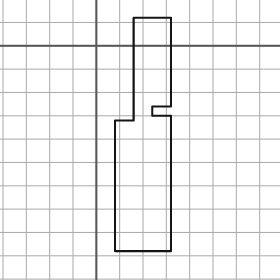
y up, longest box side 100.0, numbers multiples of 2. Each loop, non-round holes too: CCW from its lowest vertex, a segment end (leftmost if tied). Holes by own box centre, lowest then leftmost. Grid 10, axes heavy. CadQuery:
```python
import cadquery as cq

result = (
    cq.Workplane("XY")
    .moveTo(8.0, -88.0)
    .lineTo(32.0, -88.0)
    .lineTo(32.0, -30.0)
    .lineTo(24.0, -30.0)
    .lineTo(24.0, -26.0)
    .lineTo(32.0, -26.0)
    .lineTo(32.0, 12.0)
    .lineTo(16.0, 12.0)
    .lineTo(16.0, -32.0)
    .lineTo(8.0, -32.0)
    .close()
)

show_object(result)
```